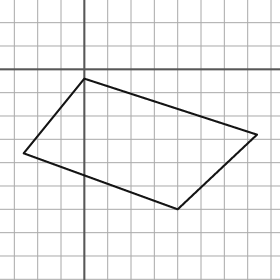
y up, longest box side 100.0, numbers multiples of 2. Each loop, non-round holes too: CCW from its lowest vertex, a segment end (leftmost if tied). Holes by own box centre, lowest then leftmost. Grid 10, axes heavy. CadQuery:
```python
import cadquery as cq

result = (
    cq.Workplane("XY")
    .moveTo(40.0, -60.0)
    .lineTo(74.0, -28.0)
    .lineTo(0.0, -4.0)
    .lineTo(-26.0, -36.0)
    .close()
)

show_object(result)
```